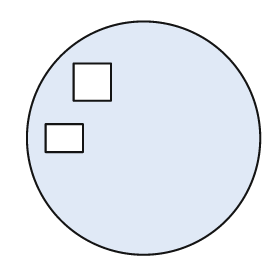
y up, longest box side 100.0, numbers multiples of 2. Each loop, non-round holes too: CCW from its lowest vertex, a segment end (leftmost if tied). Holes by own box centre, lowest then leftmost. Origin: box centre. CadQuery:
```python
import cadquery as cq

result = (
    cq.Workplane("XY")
    .moveTo(0.0, 0.0)
    .circle(50.0)
    .moveTo(-42.0, -6.0)
    .lineTo(-26.0, -6.0)
    .lineTo(-26.0, 6.0)
    .lineTo(-42.0, 6.0)
    .close()
    .moveTo(-30.0, 16.0)
    .lineTo(-14.0, 16.0)
    .lineTo(-14.0, 32.0)
    .lineTo(-30.0, 32.0)
    .close()
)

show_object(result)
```